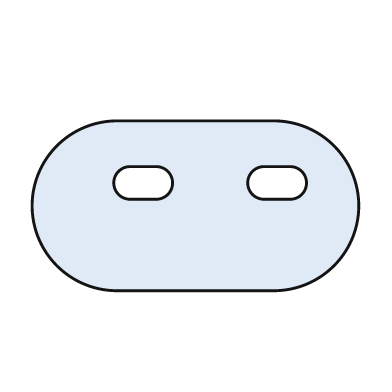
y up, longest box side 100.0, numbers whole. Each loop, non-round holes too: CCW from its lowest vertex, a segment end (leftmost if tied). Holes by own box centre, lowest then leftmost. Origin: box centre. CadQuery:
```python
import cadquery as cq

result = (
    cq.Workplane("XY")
    .moveTo(-24.0, -26.0)
    .lineTo(24.0, -26.0)
    .threePointArc((50.0, 0.0), (24.0, 26.0))
    .lineTo(-24.0, 26.0)
    .threePointArc((-50.0, 0.0), (-24.0, -26.0))
    .close()
    .moveTo(-20.0, 2.0)
    .lineTo(-12.0, 2.0)
    .threePointArc((-7.0, 7.0), (-12.0, 12.0))
    .lineTo(-20.0, 12.0)
    .threePointArc((-25.0, 7.0), (-20.0, 2.0))
    .close()
    .moveTo(21.0, 2.0)
    .lineTo(29.0, 2.0)
    .threePointArc((34.0, 7.0), (29.0, 12.0))
    .lineTo(21.0, 12.0)
    .threePointArc((16.0, 7.0), (21.0, 2.0))
    .close()
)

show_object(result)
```